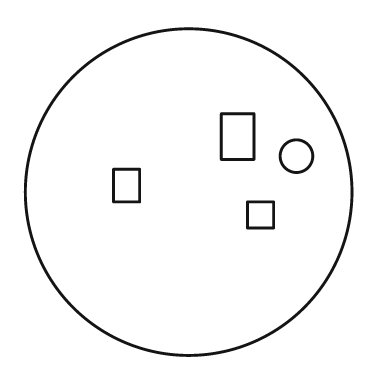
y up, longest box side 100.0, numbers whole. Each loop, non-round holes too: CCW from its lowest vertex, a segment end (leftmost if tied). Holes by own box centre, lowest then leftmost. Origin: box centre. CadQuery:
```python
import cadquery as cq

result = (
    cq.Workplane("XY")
    .moveTo(0.0, 0.0)
    .circle(50.0)
    .moveTo(18.0, -11.0)
    .lineTo(26.0, -11.0)
    .lineTo(26.0, -3.0)
    .lineTo(18.0, -3.0)
    .close()
    .moveTo(-23.0, -3.0)
    .lineTo(-15.0, -3.0)
    .lineTo(-15.0, 7.0)
    .lineTo(-23.0, 7.0)
    .close()
    .moveTo(33.0, 11.0)
    .circle(5.0)
    .moveTo(10.0, 10.0)
    .lineTo(20.0, 10.0)
    .lineTo(20.0, 24.0)
    .lineTo(10.0, 24.0)
    .close()
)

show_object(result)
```